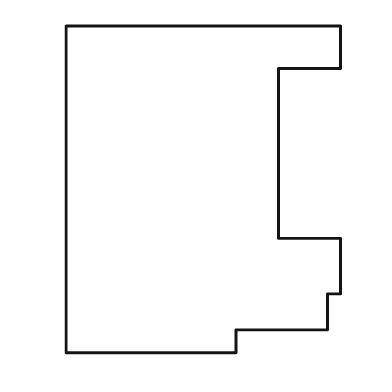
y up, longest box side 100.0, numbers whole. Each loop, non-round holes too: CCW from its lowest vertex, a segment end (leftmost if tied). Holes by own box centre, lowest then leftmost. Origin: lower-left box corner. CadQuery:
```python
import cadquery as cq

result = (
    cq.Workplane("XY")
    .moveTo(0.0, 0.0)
    .lineTo(52.0, 0.0)
    .lineTo(52.0, 7.0)
    .lineTo(80.0, 7.0)
    .lineTo(80.0, 18.0)
    .lineTo(84.0, 18.0)
    .lineTo(84.0, 35.0)
    .lineTo(65.0, 35.0)
    .lineTo(65.0, 87.0)
    .lineTo(84.0, 87.0)
    .lineTo(84.0, 100.0)
    .lineTo(0.0, 100.0)
    .close()
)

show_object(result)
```